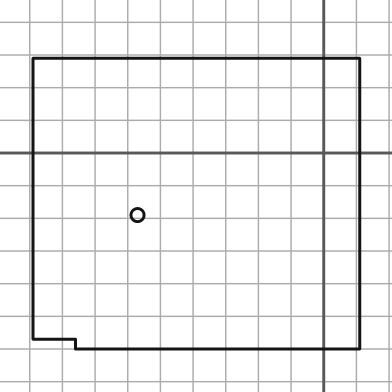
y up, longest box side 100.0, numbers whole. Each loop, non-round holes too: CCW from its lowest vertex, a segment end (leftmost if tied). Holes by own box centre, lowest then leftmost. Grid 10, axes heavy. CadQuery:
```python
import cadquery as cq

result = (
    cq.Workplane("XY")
    .moveTo(-76.0, -60.0)
    .lineTo(11.0, -60.0)
    .lineTo(11.0, 29.0)
    .lineTo(-89.0, 29.0)
    .lineTo(-89.0, -57.0)
    .lineTo(-76.0, -57.0)
    .close()
    .moveTo(-57.0, -19.0)
    .circle(2.0)
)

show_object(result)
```